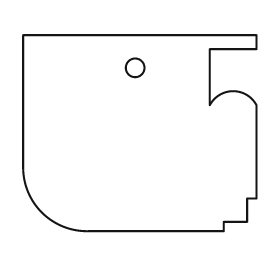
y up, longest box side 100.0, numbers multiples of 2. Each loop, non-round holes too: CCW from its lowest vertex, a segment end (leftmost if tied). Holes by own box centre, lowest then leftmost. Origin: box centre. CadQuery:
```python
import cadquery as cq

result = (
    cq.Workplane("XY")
    .moveTo(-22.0, -42.0)
    .lineTo(36.0, -42.0)
    .lineTo(36.0, -38.0)
    .lineTo(46.0, -38.0)
    .lineTo(46.0, -28.0)
    .lineTo(50.0, -28.0)
    .lineTo(50.0, 12.0)
    .threePointArc((40.0, 18.0), (30.0, 12.0))
    .lineTo(30.0, 36.0)
    .lineTo(50.0, 36.0)
    .lineTo(50.0, 42.0)
    .lineTo(-50.0, 42.0)
    .lineTo(-50.0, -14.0)
    .threePointArc((-42.0, -34.0), (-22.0, -42.0))
    .close()
    .moveTo(-2.0, 28.0)
    .circle(4.0)
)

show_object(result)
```